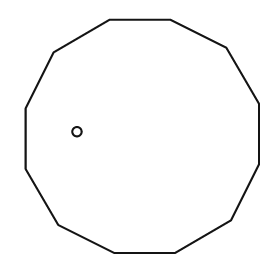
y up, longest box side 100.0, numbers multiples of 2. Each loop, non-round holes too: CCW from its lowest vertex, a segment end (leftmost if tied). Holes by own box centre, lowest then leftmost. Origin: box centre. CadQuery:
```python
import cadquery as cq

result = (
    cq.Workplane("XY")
    .moveTo(-12.0, -50.0)
    .lineTo(14.0, -50.0)
    .lineTo(38.0, -36.0)
    .lineTo(50.0, -12.0)
    .lineTo(50.0, 14.0)
    .lineTo(36.0, 38.0)
    .lineTo(12.0, 50.0)
    .lineTo(-14.0, 50.0)
    .lineTo(-38.0, 36.0)
    .lineTo(-50.0, 12.0)
    .lineTo(-50.0, -14.0)
    .lineTo(-36.0, -38.0)
    .close()
    .moveTo(-28.0, 2.0)
    .circle(2.0)
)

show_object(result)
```